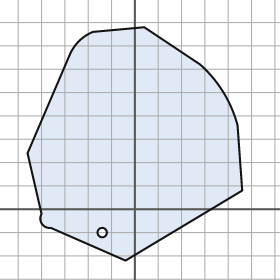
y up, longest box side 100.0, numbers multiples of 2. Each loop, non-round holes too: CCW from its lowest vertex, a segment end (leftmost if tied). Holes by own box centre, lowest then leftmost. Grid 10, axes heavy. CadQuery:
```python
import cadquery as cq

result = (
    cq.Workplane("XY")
    .moveTo(-4.0, -22.0)
    .lineTo(46.0, 8.0)
    .lineTo(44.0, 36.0)
    .threePointArc((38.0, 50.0), (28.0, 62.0))
    .lineTo(4.0, 78.0)
    .lineTo(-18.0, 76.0)
    .threePointArc((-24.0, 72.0), (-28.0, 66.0))
    .lineTo(-46.0, 24.0)
    .lineTo(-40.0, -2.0)
    .threePointArc((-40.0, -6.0), (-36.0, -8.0))
    .close()
    .moveTo(-14.0, -10.0)
    .circle(2.0)
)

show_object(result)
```